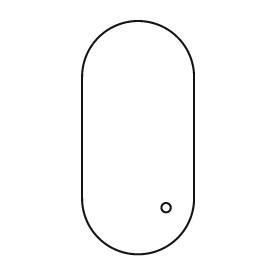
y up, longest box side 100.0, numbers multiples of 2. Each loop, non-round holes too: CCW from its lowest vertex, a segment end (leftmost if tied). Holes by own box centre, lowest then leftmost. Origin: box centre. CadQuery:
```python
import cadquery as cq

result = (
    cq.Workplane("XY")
    .moveTo(-24.0, -26.0)
    .threePointArc((0.0, -50.0), (24.0, -26.0))
    .lineTo(24.0, 26.0)
    .threePointArc((0.0, 50.0), (-24.0, 26.0))
    .close()
    .moveTo(12.0, -30.0)
    .circle(2.0)
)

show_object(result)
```